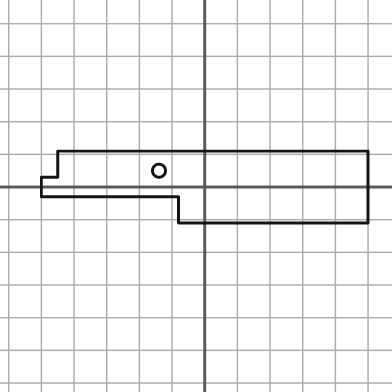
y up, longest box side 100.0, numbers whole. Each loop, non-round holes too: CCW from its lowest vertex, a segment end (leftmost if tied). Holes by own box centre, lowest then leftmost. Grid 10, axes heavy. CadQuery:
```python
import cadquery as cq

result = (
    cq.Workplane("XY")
    .moveTo(-8.0, -11.0)
    .lineTo(50.0, -11.0)
    .lineTo(50.0, 11.0)
    .lineTo(-45.0, 11.0)
    .lineTo(-45.0, 3.0)
    .lineTo(-50.0, 3.0)
    .lineTo(-50.0, -3.0)
    .lineTo(-8.0, -3.0)
    .close()
    .moveTo(-14.0, 5.0)
    .circle(2.0)
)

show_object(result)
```